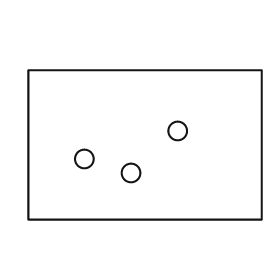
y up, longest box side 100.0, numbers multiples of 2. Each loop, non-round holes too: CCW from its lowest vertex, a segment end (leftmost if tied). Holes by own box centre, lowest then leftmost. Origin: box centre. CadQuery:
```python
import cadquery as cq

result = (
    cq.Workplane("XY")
    .moveTo(-50.0, -32.0)
    .lineTo(50.0, -32.0)
    .lineTo(50.0, 32.0)
    .lineTo(-50.0, 32.0)
    .close()
    .moveTo(-6.0, -12.0)
    .circle(4.0)
    .moveTo(-26.0, -6.0)
    .circle(4.0)
    .moveTo(14.0, 6.0)
    .circle(4.0)
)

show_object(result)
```